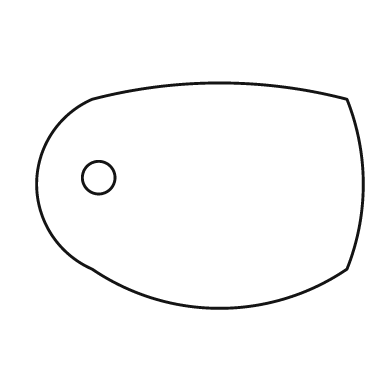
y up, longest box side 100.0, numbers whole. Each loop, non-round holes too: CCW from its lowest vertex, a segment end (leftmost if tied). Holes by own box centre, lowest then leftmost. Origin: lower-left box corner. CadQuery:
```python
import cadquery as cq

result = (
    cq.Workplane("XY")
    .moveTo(17.0, 12.0)
    .threePointArc((56.0, 0.0), (95.0, 12.0))
    .threePointArc((100.0, 38.0), (95.0, 64.0))
    .threePointArc((56.0, 69.0), (17.0, 64.0))
    .threePointArc((0.0, 38.0), (17.0, 12.0))
    .close()
    .moveTo(19.0, 40.0)
    .circle(5.0)
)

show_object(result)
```